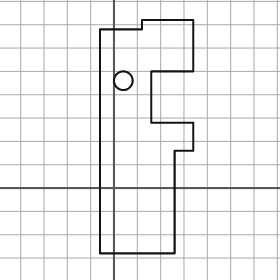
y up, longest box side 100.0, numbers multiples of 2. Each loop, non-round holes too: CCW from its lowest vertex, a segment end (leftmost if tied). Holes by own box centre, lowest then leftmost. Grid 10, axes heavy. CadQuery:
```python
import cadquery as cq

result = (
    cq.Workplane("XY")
    .moveTo(-6.0, -28.0)
    .lineTo(26.0, -28.0)
    .lineTo(26.0, 16.0)
    .lineTo(34.0, 16.0)
    .lineTo(34.0, 28.0)
    .lineTo(16.0, 28.0)
    .lineTo(16.0, 50.0)
    .lineTo(34.0, 50.0)
    .lineTo(34.0, 72.0)
    .lineTo(12.0, 72.0)
    .lineTo(12.0, 68.0)
    .lineTo(-6.0, 68.0)
    .close()
    .moveTo(4.0, 46.0)
    .circle(4.0)
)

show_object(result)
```